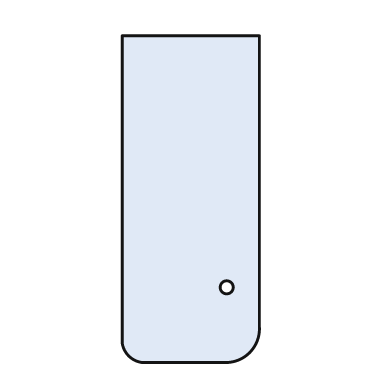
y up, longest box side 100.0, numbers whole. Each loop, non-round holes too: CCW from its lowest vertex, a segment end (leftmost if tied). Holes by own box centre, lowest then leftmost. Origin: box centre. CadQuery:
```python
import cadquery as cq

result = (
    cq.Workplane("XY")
    .moveTo(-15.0, -50.0)
    .lineTo(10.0, -50.0)
    .threePointArc((18.0, -47.0), (21.0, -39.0))
    .lineTo(21.0, 50.0)
    .lineTo(-21.0, 50.0)
    .lineTo(-21.0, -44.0)
    .threePointArc((-19.0, -48.0), (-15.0, -50.0))
    .close()
    .moveTo(11.0, -27.0)
    .circle(2.0)
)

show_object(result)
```